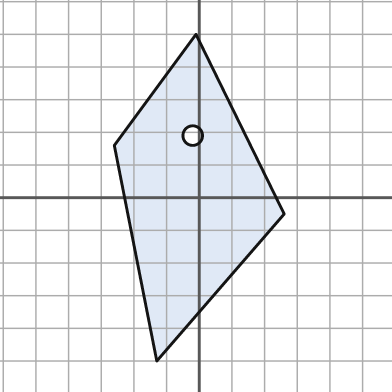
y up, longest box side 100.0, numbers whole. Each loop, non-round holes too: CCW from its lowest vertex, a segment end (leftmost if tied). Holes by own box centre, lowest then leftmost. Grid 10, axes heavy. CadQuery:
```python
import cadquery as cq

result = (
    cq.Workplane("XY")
    .moveTo(-13.0, -50.0)
    .lineTo(26.0, -5.0)
    .lineTo(-1.0, 50.0)
    .lineTo(-26.0, 16.0)
    .close()
    .moveTo(-2.0, 19.0)
    .circle(3.0)
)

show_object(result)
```